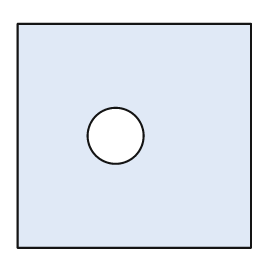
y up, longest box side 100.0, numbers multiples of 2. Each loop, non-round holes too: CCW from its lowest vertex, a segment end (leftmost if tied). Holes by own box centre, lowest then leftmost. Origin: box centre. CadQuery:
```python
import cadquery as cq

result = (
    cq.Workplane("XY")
    .moveTo(-50.0, -48.0)
    .lineTo(50.0, -48.0)
    .lineTo(50.0, 48.0)
    .lineTo(-50.0, 48.0)
    .close()
    .moveTo(-8.0, 0.0)
    .circle(12.0)
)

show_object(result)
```